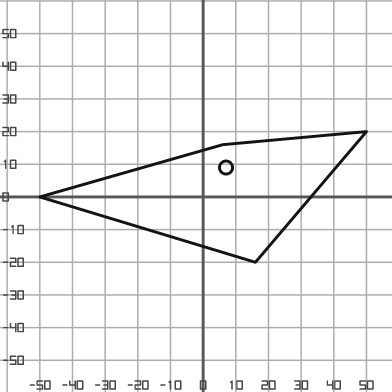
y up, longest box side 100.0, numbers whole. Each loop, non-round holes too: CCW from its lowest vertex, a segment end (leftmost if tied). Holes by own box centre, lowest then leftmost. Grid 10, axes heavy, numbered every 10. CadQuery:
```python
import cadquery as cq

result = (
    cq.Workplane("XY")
    .moveTo(16.0, -20.0)
    .lineTo(50.0, 20.0)
    .lineTo(6.0, 16.0)
    .lineTo(-50.0, 0.0)
    .close()
    .moveTo(7.0, 9.0)
    .circle(2.0)
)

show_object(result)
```